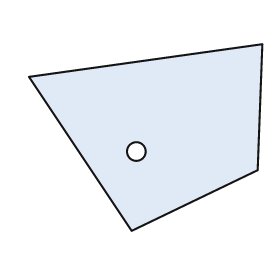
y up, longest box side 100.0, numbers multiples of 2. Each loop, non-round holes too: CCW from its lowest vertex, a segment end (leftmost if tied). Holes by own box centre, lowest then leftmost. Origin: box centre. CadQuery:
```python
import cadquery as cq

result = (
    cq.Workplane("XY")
    .moveTo(-6.0, -40.0)
    .lineTo(48.0, -14.0)
    .lineTo(50.0, 40.0)
    .lineTo(-50.0, 26.0)
    .close()
    .moveTo(-4.0, -6.0)
    .circle(4.0)
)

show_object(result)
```